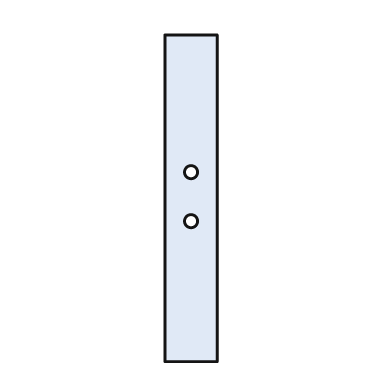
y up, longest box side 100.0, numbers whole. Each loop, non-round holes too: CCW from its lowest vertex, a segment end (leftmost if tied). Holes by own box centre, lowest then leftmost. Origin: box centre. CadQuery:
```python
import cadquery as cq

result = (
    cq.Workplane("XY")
    .moveTo(-8.0, -50.0)
    .lineTo(8.0, -50.0)
    .lineTo(8.0, 50.0)
    .lineTo(-8.0, 50.0)
    .close()
    .moveTo(0.0, -7.0)
    .circle(2.0)
    .moveTo(0.0, 8.0)
    .circle(2.0)
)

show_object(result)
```